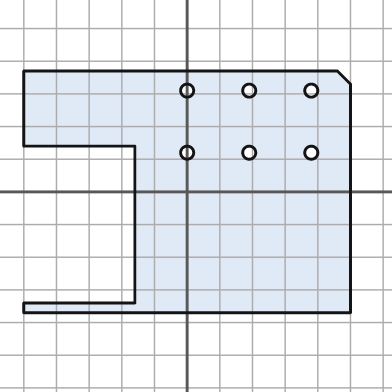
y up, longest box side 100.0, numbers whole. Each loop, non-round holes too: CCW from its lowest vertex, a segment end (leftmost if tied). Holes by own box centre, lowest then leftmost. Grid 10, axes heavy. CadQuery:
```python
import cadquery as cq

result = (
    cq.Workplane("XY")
    .moveTo(-50.0, -37.0)
    .lineTo(50.0, -37.0)
    .lineTo(50.0, 33.0)
    .lineTo(46.0, 37.0)
    .lineTo(-50.0, 37.0)
    .lineTo(-50.0, 14.0)
    .lineTo(-16.0, 14.0)
    .lineTo(-16.0, -34.0)
    .lineTo(-50.0, -34.0)
    .close()
    .moveTo(0.0, 12.0)
    .circle(2.0)
    .moveTo(19.0, 12.0)
    .circle(2.0)
    .moveTo(38.0, 12.0)
    .circle(2.0)
    .moveTo(0.0, 31.0)
    .circle(2.0)
    .moveTo(19.0, 31.0)
    .circle(2.0)
    .moveTo(38.0, 31.0)
    .circle(2.0)
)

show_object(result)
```